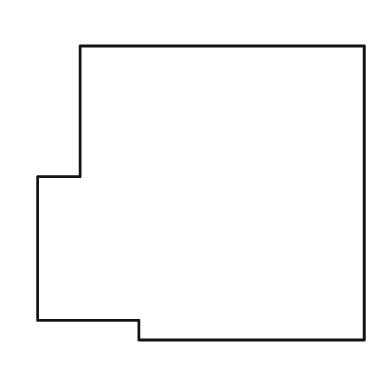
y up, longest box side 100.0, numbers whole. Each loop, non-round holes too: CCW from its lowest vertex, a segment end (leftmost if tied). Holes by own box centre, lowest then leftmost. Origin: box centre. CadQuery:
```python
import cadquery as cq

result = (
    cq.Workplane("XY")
    .moveTo(-19.0, -45.0)
    .lineTo(50.0, -45.0)
    .lineTo(50.0, 45.0)
    .lineTo(-37.0, 45.0)
    .lineTo(-37.0, 5.0)
    .lineTo(-50.0, 5.0)
    .lineTo(-50.0, -39.0)
    .lineTo(-19.0, -39.0)
    .close()
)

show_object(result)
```